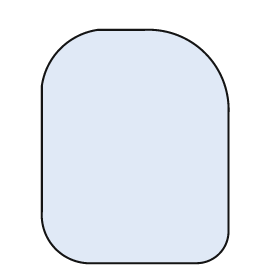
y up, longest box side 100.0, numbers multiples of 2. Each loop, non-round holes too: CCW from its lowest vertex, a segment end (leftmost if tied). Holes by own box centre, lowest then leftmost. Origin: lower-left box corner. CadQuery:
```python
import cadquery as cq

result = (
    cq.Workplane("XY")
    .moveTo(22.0, 0.0)
    .lineTo(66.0, 0.0)
    .threePointArc((76.0, 4.0), (80.0, 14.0))
    .lineTo(80.0, 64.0)
    .threePointArc((70.0, 90.0), (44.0, 100.0))
    .lineTo(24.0, 100.0)
    .threePointArc((8.0, 92.0), (0.0, 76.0))
    .lineTo(0.0, 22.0)
    .threePointArc((6.0, 6.0), (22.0, 0.0))
    .close()
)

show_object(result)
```